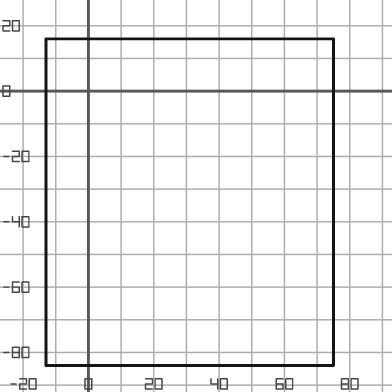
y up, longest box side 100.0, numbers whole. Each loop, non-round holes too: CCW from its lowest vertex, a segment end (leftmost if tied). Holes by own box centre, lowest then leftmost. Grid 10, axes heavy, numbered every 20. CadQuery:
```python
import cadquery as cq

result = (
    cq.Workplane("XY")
    .moveTo(-13.0, -84.0)
    .lineTo(75.0, -84.0)
    .lineTo(75.0, 16.0)
    .lineTo(-13.0, 16.0)
    .close()
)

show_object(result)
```